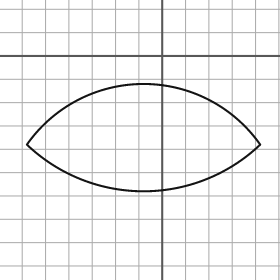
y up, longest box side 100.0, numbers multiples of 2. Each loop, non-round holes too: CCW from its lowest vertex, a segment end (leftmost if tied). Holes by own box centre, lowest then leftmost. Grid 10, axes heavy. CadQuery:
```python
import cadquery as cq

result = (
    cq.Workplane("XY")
    .moveTo(-58.0, -38.0)
    .threePointArc((-8.0, -58.0), (42.0, -38.0))
    .threePointArc((-8.0, -12.0), (-58.0, -38.0))
    .close()
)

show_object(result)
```